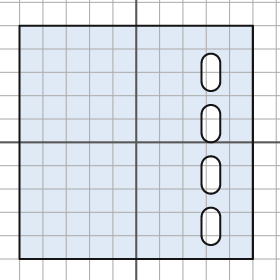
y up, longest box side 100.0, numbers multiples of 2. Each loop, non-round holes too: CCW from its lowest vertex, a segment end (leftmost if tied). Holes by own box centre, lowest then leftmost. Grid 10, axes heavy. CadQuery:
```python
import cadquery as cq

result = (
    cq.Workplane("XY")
    .moveTo(-50.0, -50.0)
    .lineTo(50.0, -50.0)
    .lineTo(50.0, 50.0)
    .lineTo(-50.0, 50.0)
    .close()
    .moveTo(28.0, -40.0)
    .threePointArc((32.0, -44.0), (36.0, -40.0))
    .lineTo(36.0, -32.0)
    .threePointArc((32.0, -28.0), (28.0, -32.0))
    .close()
    .moveTo(28.0, -18.0)
    .threePointArc((32.0, -22.0), (36.0, -18.0))
    .lineTo(36.0, -10.0)
    .threePointArc((32.0, -6.0), (28.0, -10.0))
    .close()
    .moveTo(28.0, 4.0)
    .threePointArc((32.0, 0.0), (36.0, 4.0))
    .lineTo(36.0, 12.0)
    .threePointArc((32.0, 16.0), (28.0, 12.0))
    .close()
    .moveTo(28.0, 26.0)
    .threePointArc((32.0, 22.0), (36.0, 26.0))
    .lineTo(36.0, 34.0)
    .threePointArc((32.0, 38.0), (28.0, 34.0))
    .close()
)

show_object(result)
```